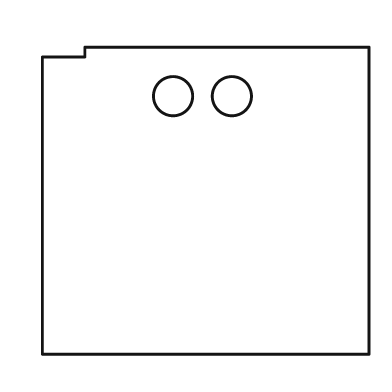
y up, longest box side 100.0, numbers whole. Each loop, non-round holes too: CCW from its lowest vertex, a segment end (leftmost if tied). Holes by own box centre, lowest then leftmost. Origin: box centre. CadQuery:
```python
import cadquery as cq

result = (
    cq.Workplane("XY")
    .moveTo(-50.0, -47.0)
    .lineTo(50.0, -47.0)
    .lineTo(50.0, 47.0)
    .lineTo(-37.0, 47.0)
    .lineTo(-37.0, 44.0)
    .lineTo(-50.0, 44.0)
    .close()
    .moveTo(-10.0, 32.0)
    .circle(6.0)
    .moveTo(8.0, 32.0)
    .circle(6.0)
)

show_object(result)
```